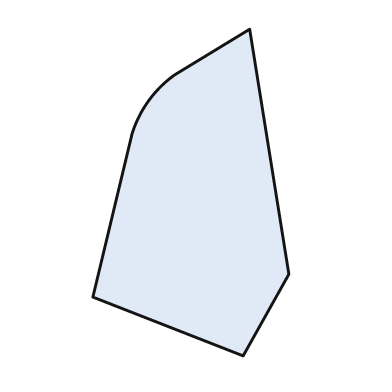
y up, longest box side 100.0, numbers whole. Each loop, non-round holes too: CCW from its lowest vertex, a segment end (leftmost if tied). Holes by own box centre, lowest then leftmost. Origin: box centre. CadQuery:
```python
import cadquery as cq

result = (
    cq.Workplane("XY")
    .moveTo(16.0, -50.0)
    .lineTo(30.0, -25.0)
    .lineTo(18.0, 50.0)
    .lineTo(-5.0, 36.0)
    .threePointArc((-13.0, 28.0), (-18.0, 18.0))
    .lineTo(-30.0, -32.0)
    .close()
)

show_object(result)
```